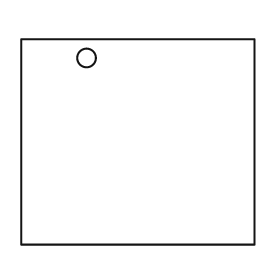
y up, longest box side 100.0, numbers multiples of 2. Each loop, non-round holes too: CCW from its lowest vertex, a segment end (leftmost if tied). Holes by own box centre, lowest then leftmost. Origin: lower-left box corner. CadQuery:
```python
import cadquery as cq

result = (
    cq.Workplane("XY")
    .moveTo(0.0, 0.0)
    .lineTo(100.0, 0.0)
    .lineTo(100.0, 88.0)
    .lineTo(0.0, 88.0)
    .close()
    .moveTo(28.0, 80.0)
    .circle(4.0)
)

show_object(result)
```